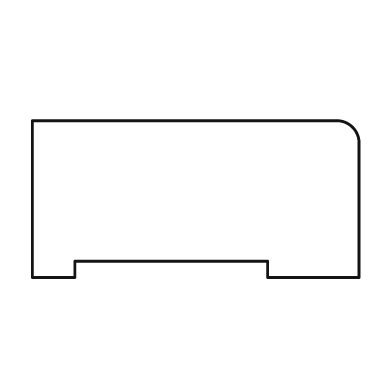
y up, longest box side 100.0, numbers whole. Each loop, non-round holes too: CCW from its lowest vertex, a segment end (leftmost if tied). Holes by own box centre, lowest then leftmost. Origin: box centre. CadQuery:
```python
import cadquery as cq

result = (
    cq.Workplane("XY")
    .moveTo(-50.0, -24.0)
    .lineTo(-37.0, -24.0)
    .lineTo(-37.0, -19.0)
    .lineTo(22.0, -19.0)
    .lineTo(22.0, -24.0)
    .lineTo(50.0, -24.0)
    .lineTo(50.0, 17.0)
    .threePointArc((48.0, 22.0), (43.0, 24.0))
    .lineTo(-50.0, 24.0)
    .close()
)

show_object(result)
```